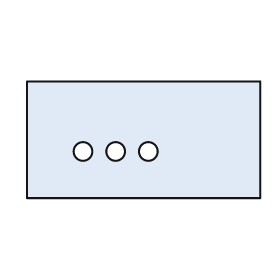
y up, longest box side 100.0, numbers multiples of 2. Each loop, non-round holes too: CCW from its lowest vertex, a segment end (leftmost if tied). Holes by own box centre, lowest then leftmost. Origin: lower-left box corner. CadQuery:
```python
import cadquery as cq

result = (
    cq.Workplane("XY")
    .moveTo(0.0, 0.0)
    .lineTo(100.0, 0.0)
    .lineTo(100.0, 50.0)
    .lineTo(0.0, 50.0)
    .close()
    .moveTo(24.0, 20.0)
    .circle(4.0)
    .moveTo(38.0, 20.0)
    .circle(4.0)
    .moveTo(52.0, 20.0)
    .circle(4.0)
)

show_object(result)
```